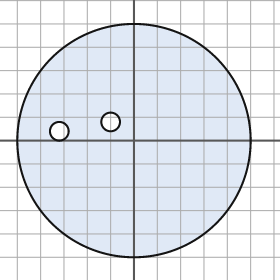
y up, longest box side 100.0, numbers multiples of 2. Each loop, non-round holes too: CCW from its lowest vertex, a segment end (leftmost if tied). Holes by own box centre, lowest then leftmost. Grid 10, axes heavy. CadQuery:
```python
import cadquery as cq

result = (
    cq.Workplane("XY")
    .moveTo(0.0, 0.0)
    .circle(50.0)
    .moveTo(-32.0, 4.0)
    .circle(4.0)
    .moveTo(-10.0, 8.0)
    .circle(4.0)
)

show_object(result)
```